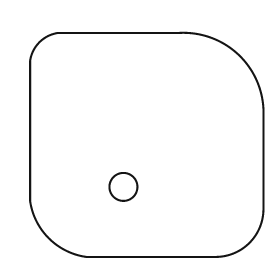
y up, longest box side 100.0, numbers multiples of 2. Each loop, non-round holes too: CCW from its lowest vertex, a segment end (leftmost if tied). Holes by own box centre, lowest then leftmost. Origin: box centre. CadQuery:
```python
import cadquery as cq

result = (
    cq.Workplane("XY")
    .moveTo(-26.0, -48.0)
    .lineTo(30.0, -48.0)
    .threePointArc((44.0, -42.0), (50.0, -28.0))
    .lineTo(50.0, 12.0)
    .threePointArc((40.0, 38.0), (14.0, 48.0))
    .lineTo(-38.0, 48.0)
    .threePointArc((-46.0, 44.0), (-50.0, 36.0))
    .lineTo(-50.0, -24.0)
    .threePointArc((-42.0, -40.0), (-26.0, -48.0))
    .close()
    .moveTo(-10.0, -18.0)
    .circle(6.0)
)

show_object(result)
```